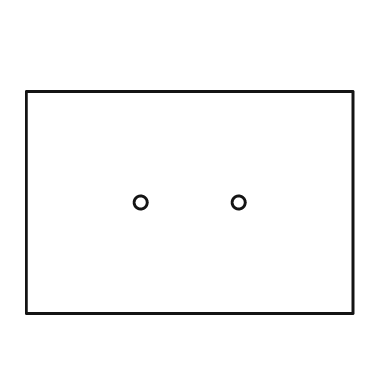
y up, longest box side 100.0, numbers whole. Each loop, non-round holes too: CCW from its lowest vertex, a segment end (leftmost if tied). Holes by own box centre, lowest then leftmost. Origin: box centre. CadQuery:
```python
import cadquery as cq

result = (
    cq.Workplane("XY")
    .moveTo(-50.0, -34.0)
    .lineTo(50.0, -34.0)
    .lineTo(50.0, 34.0)
    .lineTo(-50.0, 34.0)
    .close()
    .moveTo(-15.0, 0.0)
    .circle(2.0)
    .moveTo(15.0, 0.0)
    .circle(2.0)
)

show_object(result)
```